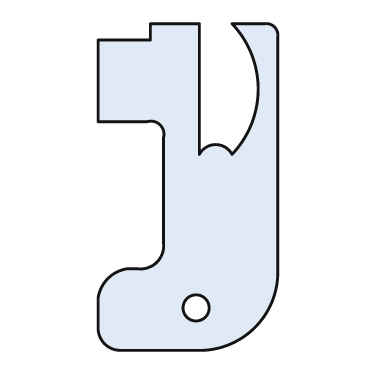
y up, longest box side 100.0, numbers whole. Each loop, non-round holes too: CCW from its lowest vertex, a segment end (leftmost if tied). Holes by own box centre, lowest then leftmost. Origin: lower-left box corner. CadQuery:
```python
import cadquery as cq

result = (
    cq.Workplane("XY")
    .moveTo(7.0, 0.0)
    .lineTo(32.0, 0.0)
    .threePointArc((48.0, 7.0), (55.0, 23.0))
    .lineTo(55.0, 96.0)
    .threePointArc((54.0, 99.0), (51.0, 100.0))
    .lineTo(41.0, 100.0)
    .threePointArc((49.0, 80.0), (41.0, 60.0))
    .threePointArc((36.0, 63.0), (31.0, 60.0))
    .lineTo(31.0, 100.0)
    .lineTo(16.0, 100.0)
    .lineTo(16.0, 95.0)
    .lineTo(0.0, 95.0)
    .lineTo(0.0, 70.0)
    .lineTo(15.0, 70.0)
    .threePointArc((19.0, 69.0), (20.0, 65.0))
    .lineTo(20.0, 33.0)
    .threePointArc((18.0, 27.0), (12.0, 25.0))
    .lineTo(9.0, 25.0)
    .threePointArc((3.0, 22.0), (0.0, 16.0))
    .lineTo(0.0, 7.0)
    .threePointArc((2.0, 2.0), (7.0, 0.0))
    .close()
    .moveTo(30.0, 13.0)
    .circle(4.0)
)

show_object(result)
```